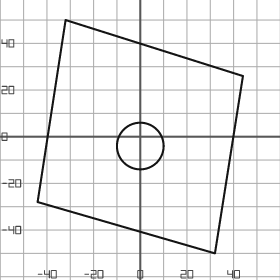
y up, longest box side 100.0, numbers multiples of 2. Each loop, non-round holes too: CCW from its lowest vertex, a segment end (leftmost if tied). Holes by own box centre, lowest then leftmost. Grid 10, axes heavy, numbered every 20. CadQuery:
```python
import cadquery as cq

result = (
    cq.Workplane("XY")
    .moveTo(32.0, -50.0)
    .lineTo(44.0, 26.0)
    .lineTo(-32.0, 50.0)
    .lineTo(-44.0, -28.0)
    .close()
    .moveTo(0.0, -4.0)
    .circle(10.0)
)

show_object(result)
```